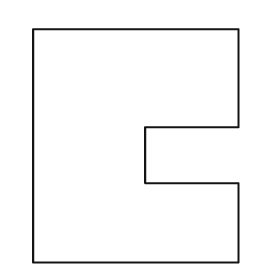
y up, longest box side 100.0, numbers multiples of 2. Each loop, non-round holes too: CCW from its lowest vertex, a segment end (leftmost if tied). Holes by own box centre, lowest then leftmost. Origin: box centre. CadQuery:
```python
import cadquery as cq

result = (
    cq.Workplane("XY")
    .moveTo(-44.0, -50.0)
    .lineTo(44.0, -50.0)
    .lineTo(44.0, -16.0)
    .lineTo(4.0, -16.0)
    .lineTo(4.0, 8.0)
    .lineTo(44.0, 8.0)
    .lineTo(44.0, 50.0)
    .lineTo(-44.0, 50.0)
    .close()
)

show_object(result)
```